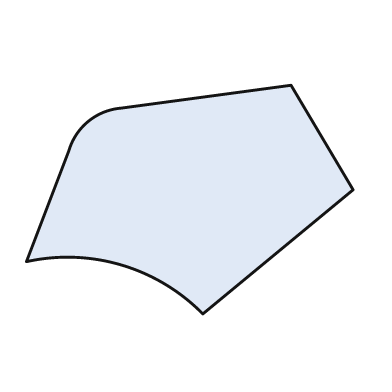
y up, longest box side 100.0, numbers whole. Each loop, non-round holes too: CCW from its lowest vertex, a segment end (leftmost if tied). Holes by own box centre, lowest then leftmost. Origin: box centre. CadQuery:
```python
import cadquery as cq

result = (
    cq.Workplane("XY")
    .moveTo(4.0, -35.0)
    .lineTo(50.0, 3.0)
    .lineTo(31.0, 35.0)
    .lineTo(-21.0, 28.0)
    .threePointArc((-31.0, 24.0), (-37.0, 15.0))
    .lineTo(-50.0, -19.0)
    .threePointArc((-21.0, -20.0), (4.0, -35.0))
    .close()
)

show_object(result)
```